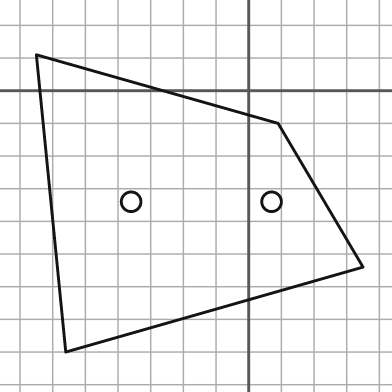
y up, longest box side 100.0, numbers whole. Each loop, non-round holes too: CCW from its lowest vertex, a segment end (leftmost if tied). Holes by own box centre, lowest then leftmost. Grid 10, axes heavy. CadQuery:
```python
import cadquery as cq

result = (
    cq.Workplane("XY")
    .moveTo(-56.0, -80.0)
    .lineTo(35.0, -54.0)
    .lineTo(9.0, -10.0)
    .lineTo(-65.0, 11.0)
    .close()
    .moveTo(-36.0, -34.0)
    .circle(3.0)
    .moveTo(7.0, -34.0)
    .circle(3.0)
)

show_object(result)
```